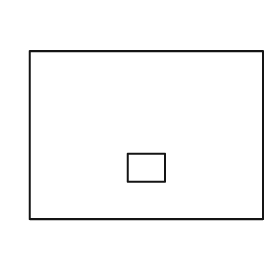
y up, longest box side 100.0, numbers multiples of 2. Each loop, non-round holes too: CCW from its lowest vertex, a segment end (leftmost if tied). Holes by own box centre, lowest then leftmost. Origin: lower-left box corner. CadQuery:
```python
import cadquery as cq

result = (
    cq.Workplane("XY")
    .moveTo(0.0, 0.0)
    .lineTo(100.0, 0.0)
    .lineTo(100.0, 72.0)
    .lineTo(0.0, 72.0)
    .close()
    .moveTo(42.0, 16.0)
    .lineTo(58.0, 16.0)
    .lineTo(58.0, 28.0)
    .lineTo(42.0, 28.0)
    .close()
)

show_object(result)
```